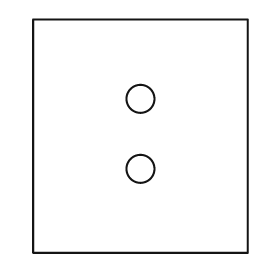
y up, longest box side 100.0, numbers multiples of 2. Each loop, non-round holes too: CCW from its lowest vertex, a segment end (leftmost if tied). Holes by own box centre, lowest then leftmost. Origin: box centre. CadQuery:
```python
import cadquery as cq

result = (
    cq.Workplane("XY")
    .moveTo(-46.0, -50.0)
    .lineTo(46.0, -50.0)
    .lineTo(46.0, 50.0)
    .lineTo(-46.0, 50.0)
    .close()
    .moveTo(0.0, -14.0)
    .circle(6.0)
    .moveTo(0.0, 16.0)
    .circle(6.0)
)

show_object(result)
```